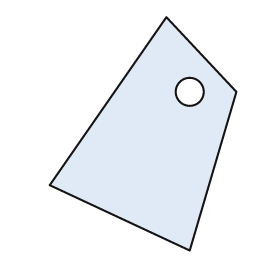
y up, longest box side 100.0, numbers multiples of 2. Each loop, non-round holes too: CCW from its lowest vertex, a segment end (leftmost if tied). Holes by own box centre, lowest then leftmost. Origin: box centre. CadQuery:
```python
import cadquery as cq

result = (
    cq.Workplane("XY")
    .moveTo(20.0, -50.0)
    .lineTo(40.0, 18.0)
    .lineTo(10.0, 50.0)
    .lineTo(-40.0, -22.0)
    .close()
    .moveTo(20.0, 18.0)
    .circle(6.0)
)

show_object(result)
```